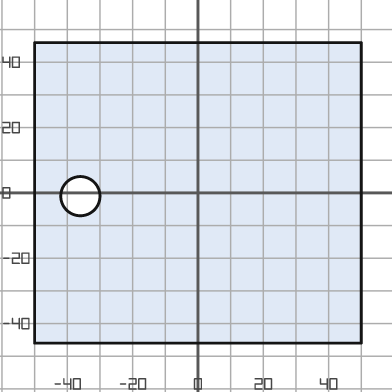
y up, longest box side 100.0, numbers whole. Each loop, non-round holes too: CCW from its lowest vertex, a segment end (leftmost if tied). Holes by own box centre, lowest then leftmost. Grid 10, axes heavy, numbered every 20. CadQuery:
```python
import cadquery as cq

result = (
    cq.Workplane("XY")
    .moveTo(-50.0, -46.0)
    .lineTo(50.0, -46.0)
    .lineTo(50.0, 46.0)
    .lineTo(-50.0, 46.0)
    .close()
    .moveTo(-36.0, -1.0)
    .circle(6.0)
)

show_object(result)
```